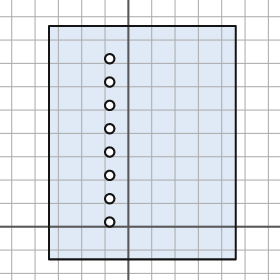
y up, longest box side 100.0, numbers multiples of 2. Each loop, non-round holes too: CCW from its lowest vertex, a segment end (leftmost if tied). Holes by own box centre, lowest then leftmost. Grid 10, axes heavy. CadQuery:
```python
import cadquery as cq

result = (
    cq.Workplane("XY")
    .moveTo(-34.0, -14.0)
    .lineTo(46.0, -14.0)
    .lineTo(46.0, 86.0)
    .lineTo(-34.0, 86.0)
    .close()
    .moveTo(-8.0, 2.0)
    .circle(2.0)
    .moveTo(-8.0, 12.0)
    .circle(2.0)
    .moveTo(-8.0, 22.0)
    .circle(2.0)
    .moveTo(-8.0, 32.0)
    .circle(2.0)
    .moveTo(-8.0, 42.0)
    .circle(2.0)
    .moveTo(-8.0, 52.0)
    .circle(2.0)
    .moveTo(-8.0, 62.0)
    .circle(2.0)
    .moveTo(-8.0, 72.0)
    .circle(2.0)
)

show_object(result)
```